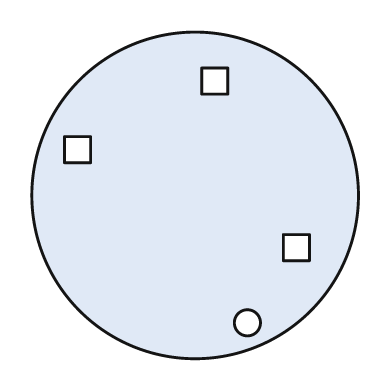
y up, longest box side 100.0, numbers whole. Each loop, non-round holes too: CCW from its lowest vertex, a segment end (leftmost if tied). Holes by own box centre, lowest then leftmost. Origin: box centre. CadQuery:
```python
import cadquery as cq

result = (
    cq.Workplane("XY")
    .moveTo(0.0, 0.0)
    .circle(50.0)
    .moveTo(16.0, -39.0)
    .circle(4.0)
    .moveTo(27.0, -20.0)
    .lineTo(35.0, -20.0)
    .lineTo(35.0, -12.0)
    .lineTo(27.0, -12.0)
    .close()
    .moveTo(-40.0, 10.0)
    .lineTo(-32.0, 10.0)
    .lineTo(-32.0, 18.0)
    .lineTo(-40.0, 18.0)
    .close()
    .moveTo(2.0, 31.0)
    .lineTo(10.0, 31.0)
    .lineTo(10.0, 39.0)
    .lineTo(2.0, 39.0)
    .close()
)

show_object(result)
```